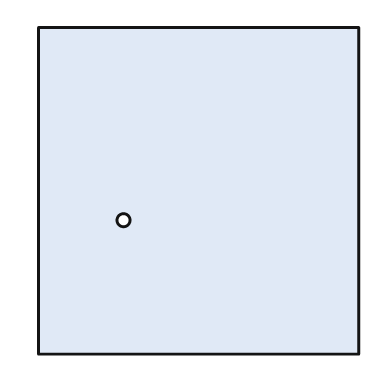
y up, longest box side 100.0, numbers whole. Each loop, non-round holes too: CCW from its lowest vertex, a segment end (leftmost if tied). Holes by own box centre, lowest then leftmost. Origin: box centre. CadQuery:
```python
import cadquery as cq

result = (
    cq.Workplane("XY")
    .moveTo(-49.0, -50.0)
    .lineTo(49.0, -50.0)
    .lineTo(49.0, 50.0)
    .lineTo(-49.0, 50.0)
    .close()
    .moveTo(-23.0, -9.0)
    .circle(2.0)
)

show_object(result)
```